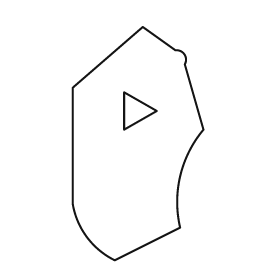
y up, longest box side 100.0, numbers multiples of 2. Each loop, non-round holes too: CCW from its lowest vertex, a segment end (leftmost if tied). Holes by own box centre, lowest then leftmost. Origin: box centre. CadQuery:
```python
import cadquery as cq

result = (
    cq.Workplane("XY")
    .moveTo(-10.0, -50.0)
    .lineTo(18.0, -36.0)
    .threePointArc((18.0, -14.0), (28.0, 6.0))
    .lineTo(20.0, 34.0)
    .threePointArc((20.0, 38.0), (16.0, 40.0))
    .lineTo(2.0, 50.0)
    .lineTo(-28.0, 24.0)
    .lineTo(-28.0, -26.0)
    .threePointArc((-22.0, -40.0), (-10.0, -50.0))
    .close()
    .moveTo(-6.0, 6.0)
    .lineTo(8.0, 14.0)
    .lineTo(-6.0, 22.0)
    .close()
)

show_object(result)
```